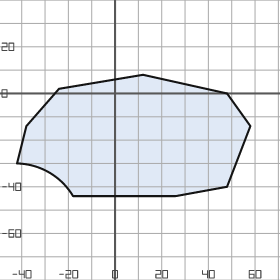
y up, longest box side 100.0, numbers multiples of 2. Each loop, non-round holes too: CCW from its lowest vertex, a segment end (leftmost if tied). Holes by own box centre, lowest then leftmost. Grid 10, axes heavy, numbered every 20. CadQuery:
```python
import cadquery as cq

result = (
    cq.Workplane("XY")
    .moveTo(-18.0, -44.0)
    .lineTo(26.0, -44.0)
    .lineTo(48.0, -40.0)
    .lineTo(58.0, -14.0)
    .lineTo(48.0, 0.0)
    .lineTo(12.0, 8.0)
    .lineTo(-24.0, 2.0)
    .lineTo(-38.0, -14.0)
    .lineTo(-42.0, -30.0)
    .threePointArc((-28.0, -34.0), (-18.0, -44.0))
    .close()
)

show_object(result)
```